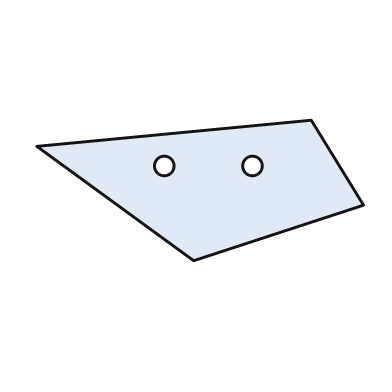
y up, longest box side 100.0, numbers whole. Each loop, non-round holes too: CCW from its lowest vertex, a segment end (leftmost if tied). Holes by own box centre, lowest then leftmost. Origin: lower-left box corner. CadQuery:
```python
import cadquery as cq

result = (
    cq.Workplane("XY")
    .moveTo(48.0, 0.0)
    .lineTo(100.0, 17.0)
    .lineTo(84.0, 43.0)
    .lineTo(0.0, 35.0)
    .close()
    .moveTo(39.0, 29.0)
    .circle(3.0)
    .moveTo(66.0, 29.0)
    .circle(3.0)
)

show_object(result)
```